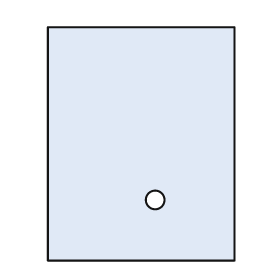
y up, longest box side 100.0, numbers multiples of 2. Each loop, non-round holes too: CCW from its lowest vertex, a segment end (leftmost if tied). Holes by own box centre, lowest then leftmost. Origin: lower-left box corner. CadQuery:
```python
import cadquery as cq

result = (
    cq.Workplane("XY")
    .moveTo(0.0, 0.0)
    .lineTo(80.0, 0.0)
    .lineTo(80.0, 100.0)
    .lineTo(0.0, 100.0)
    .close()
    .moveTo(46.0, 26.0)
    .circle(4.0)
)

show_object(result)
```